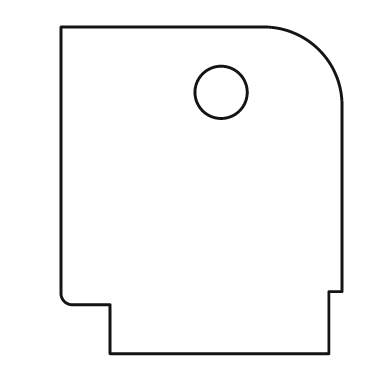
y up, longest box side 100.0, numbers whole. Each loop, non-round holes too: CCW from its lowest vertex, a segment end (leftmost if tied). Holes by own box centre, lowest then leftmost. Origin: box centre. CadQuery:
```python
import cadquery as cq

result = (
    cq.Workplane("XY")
    .moveTo(-28.0, -50.0)
    .lineTo(39.0, -50.0)
    .lineTo(39.0, -31.0)
    .lineTo(43.0, -31.0)
    .lineTo(43.0, 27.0)
    .threePointArc((36.0, 43.0), (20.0, 50.0))
    .lineTo(-43.0, 50.0)
    .lineTo(-43.0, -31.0)
    .threePointArc((-42.0, -34.0), (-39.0, -35.0))
    .lineTo(-28.0, -35.0)
    .close()
    .moveTo(6.0, 30.0)
    .circle(8.0)
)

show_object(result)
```